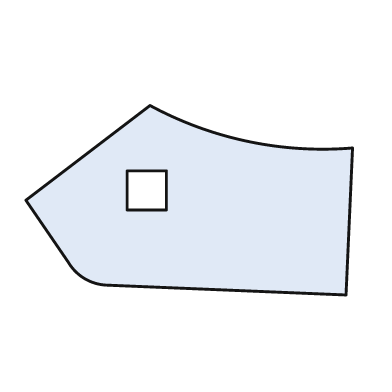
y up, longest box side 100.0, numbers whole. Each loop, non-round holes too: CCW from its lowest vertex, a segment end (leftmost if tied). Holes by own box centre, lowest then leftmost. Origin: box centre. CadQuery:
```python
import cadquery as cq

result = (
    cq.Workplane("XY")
    .moveTo(48.0, -29.0)
    .lineTo(50.0, 16.0)
    .threePointArc((18.0, 18.0), (-12.0, 29.0))
    .lineTo(-50.0, 0.0)
    .lineTo(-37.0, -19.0)
    .threePointArc((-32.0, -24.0), (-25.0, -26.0))
    .close()
    .moveTo(-19.0, -3.0)
    .lineTo(-7.0, -3.0)
    .lineTo(-7.0, 9.0)
    .lineTo(-19.0, 9.0)
    .close()
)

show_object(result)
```